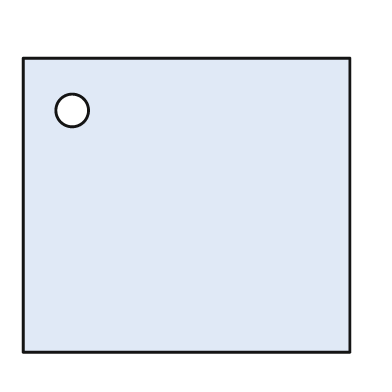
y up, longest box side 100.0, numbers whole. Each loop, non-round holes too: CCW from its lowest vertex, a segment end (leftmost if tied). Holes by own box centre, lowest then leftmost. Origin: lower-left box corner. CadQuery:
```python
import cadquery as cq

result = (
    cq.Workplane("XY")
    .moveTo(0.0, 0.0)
    .lineTo(100.0, 0.0)
    .lineTo(100.0, 90.0)
    .lineTo(0.0, 90.0)
    .close()
    .moveTo(15.0, 74.0)
    .circle(5.0)
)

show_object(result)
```